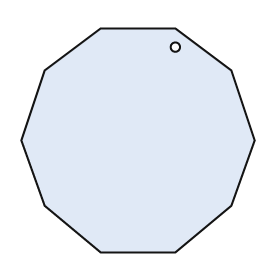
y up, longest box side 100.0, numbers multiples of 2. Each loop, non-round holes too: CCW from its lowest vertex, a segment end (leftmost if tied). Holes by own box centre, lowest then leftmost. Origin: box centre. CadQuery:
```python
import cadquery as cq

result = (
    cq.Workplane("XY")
    .moveTo(-16.0, -48.0)
    .lineTo(16.0, -48.0)
    .lineTo(40.0, -28.0)
    .lineTo(50.0, 0.0)
    .lineTo(40.0, 30.0)
    .lineTo(16.0, 48.0)
    .lineTo(-16.0, 48.0)
    .lineTo(-40.0, 30.0)
    .lineTo(-50.0, 0.0)
    .lineTo(-40.0, -28.0)
    .close()
    .moveTo(16.0, 40.0)
    .circle(2.0)
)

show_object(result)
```